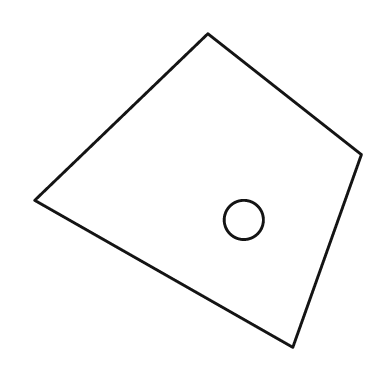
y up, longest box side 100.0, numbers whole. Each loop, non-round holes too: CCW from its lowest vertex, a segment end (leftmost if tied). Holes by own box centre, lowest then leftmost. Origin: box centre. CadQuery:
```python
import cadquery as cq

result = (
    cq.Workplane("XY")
    .moveTo(29.0, -48.0)
    .lineTo(50.0, 11.0)
    .lineTo(3.0, 48.0)
    .lineTo(-50.0, -3.0)
    .close()
    .moveTo(14.0, -9.0)
    .circle(6.0)
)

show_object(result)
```